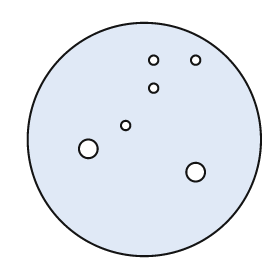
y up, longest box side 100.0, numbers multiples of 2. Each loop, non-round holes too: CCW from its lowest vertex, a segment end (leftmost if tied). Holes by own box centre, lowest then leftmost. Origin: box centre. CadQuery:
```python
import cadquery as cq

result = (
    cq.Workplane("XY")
    .moveTo(0.0, 0.0)
    .circle(50.0)
    .moveTo(22.0, -14.0)
    .circle(4.0)
    .moveTo(-24.0, -4.0)
    .circle(4.0)
    .moveTo(-8.0, 6.0)
    .circle(2.0)
    .moveTo(4.0, 22.0)
    .circle(2.0)
    .moveTo(4.0, 34.0)
    .circle(2.0)
    .moveTo(22.0, 34.0)
    .circle(2.0)
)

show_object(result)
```